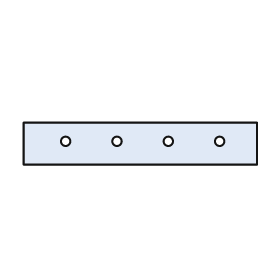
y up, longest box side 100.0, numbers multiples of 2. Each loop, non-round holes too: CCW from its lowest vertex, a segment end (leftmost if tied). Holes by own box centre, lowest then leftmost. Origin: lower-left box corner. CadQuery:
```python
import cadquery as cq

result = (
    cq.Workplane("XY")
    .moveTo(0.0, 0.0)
    .lineTo(100.0, 0.0)
    .lineTo(100.0, 18.0)
    .lineTo(0.0, 18.0)
    .close()
    .moveTo(18.0, 10.0)
    .circle(2.0)
    .moveTo(40.0, 10.0)
    .circle(2.0)
    .moveTo(62.0, 10.0)
    .circle(2.0)
    .moveTo(84.0, 10.0)
    .circle(2.0)
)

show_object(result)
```